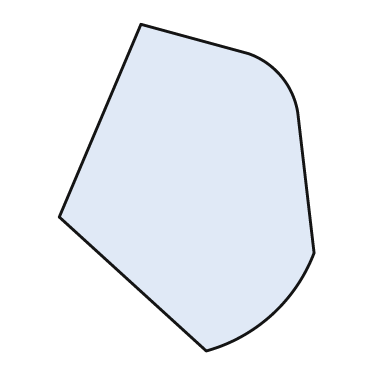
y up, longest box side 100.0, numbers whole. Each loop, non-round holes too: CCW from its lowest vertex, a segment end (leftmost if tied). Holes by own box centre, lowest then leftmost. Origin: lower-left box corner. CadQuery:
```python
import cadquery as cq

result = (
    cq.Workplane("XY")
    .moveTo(45.0, 0.0)
    .threePointArc((65.0, 11.0), (78.0, 30.0))
    .lineTo(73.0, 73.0)
    .threePointArc((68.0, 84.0), (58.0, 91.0))
    .lineTo(25.0, 100.0)
    .lineTo(0.0, 41.0)
    .close()
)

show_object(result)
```